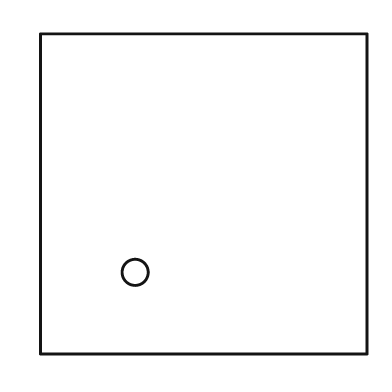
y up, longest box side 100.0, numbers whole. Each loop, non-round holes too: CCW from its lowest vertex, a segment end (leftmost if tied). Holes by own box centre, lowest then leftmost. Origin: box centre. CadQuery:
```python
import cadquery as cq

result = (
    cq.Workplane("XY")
    .moveTo(-50.0, -49.0)
    .lineTo(50.0, -49.0)
    .lineTo(50.0, 49.0)
    .lineTo(-50.0, 49.0)
    .close()
    .moveTo(-21.0, -24.0)
    .circle(4.0)
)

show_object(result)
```